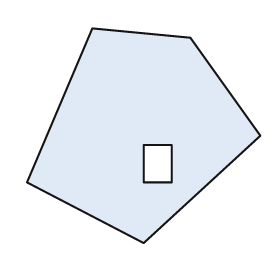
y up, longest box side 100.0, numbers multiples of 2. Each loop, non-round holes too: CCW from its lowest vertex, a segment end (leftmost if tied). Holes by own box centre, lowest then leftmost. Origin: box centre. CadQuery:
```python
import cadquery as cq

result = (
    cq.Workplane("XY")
    .moveTo(0.0, -46.0)
    .lineTo(50.0, 0.0)
    .lineTo(20.0, 42.0)
    .lineTo(-22.0, 46.0)
    .lineTo(-50.0, -20.0)
    .close()
    .moveTo(0.0, -20.0)
    .lineTo(12.0, -20.0)
    .lineTo(12.0, -4.0)
    .lineTo(0.0, -4.0)
    .close()
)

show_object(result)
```